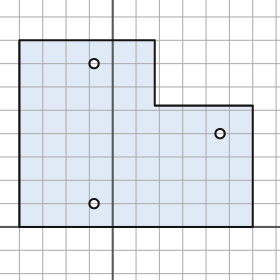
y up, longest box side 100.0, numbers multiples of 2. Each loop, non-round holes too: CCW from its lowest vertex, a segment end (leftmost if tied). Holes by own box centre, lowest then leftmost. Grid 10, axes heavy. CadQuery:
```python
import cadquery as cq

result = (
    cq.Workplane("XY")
    .moveTo(-40.0, 0.0)
    .lineTo(60.0, 0.0)
    .lineTo(60.0, 52.0)
    .lineTo(18.0, 52.0)
    .lineTo(18.0, 80.0)
    .lineTo(-40.0, 80.0)
    .close()
    .moveTo(-8.0, 10.0)
    .circle(2.0)
    .moveTo(46.0, 40.0)
    .circle(2.0)
    .moveTo(-8.0, 70.0)
    .circle(2.0)
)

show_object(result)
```